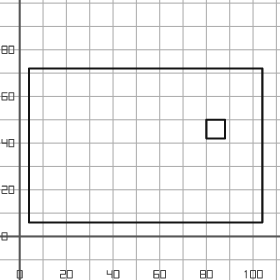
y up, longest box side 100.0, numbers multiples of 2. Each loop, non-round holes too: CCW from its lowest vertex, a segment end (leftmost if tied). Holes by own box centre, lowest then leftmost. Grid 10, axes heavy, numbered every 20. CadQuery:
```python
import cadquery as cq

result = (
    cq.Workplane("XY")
    .moveTo(4.0, 6.0)
    .lineTo(104.0, 6.0)
    .lineTo(104.0, 72.0)
    .lineTo(4.0, 72.0)
    .close()
    .moveTo(80.0, 42.0)
    .lineTo(88.0, 42.0)
    .lineTo(88.0, 50.0)
    .lineTo(80.0, 50.0)
    .close()
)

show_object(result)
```